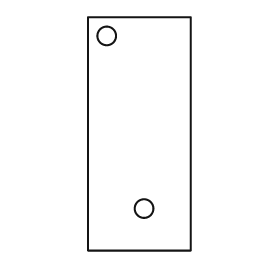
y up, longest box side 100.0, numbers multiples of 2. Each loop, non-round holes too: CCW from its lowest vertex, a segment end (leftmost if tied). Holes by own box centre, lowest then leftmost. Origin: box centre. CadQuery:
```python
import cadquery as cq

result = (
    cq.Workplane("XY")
    .moveTo(-22.0, -50.0)
    .lineTo(22.0, -50.0)
    .lineTo(22.0, 50.0)
    .lineTo(-22.0, 50.0)
    .close()
    .moveTo(2.0, -32.0)
    .circle(4.0)
    .moveTo(-14.0, 42.0)
    .circle(4.0)
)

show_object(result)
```